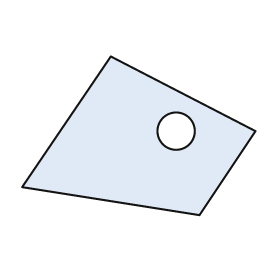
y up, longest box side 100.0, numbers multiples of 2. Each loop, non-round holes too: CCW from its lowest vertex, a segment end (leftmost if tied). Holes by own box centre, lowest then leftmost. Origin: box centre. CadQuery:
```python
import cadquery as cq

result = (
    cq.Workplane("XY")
    .moveTo(26.0, -34.0)
    .lineTo(50.0, 2.0)
    .lineTo(-12.0, 34.0)
    .lineTo(-50.0, -22.0)
    .close()
    .moveTo(16.0, 2.0)
    .circle(8.0)
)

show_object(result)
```